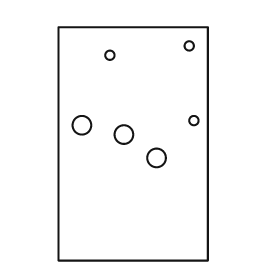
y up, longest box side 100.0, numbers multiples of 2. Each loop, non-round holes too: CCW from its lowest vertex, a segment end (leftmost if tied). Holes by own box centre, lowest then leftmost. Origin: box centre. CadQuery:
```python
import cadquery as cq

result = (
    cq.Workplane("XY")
    .moveTo(-32.0, -50.0)
    .lineTo(32.0, -50.0)
    .lineTo(32.0, 50.0)
    .lineTo(-32.0, 50.0)
    .close()
    .moveTo(10.0, -6.0)
    .circle(4.0)
    .moveTo(-4.0, 4.0)
    .circle(4.0)
    .moveTo(-22.0, 8.0)
    .circle(4.0)
    .moveTo(26.0, 10.0)
    .circle(2.0)
    .moveTo(-10.0, 38.0)
    .circle(2.0)
    .moveTo(24.0, 42.0)
    .circle(2.0)
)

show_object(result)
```